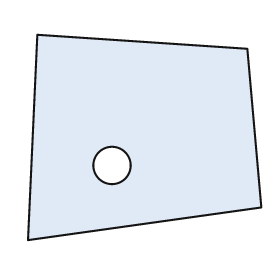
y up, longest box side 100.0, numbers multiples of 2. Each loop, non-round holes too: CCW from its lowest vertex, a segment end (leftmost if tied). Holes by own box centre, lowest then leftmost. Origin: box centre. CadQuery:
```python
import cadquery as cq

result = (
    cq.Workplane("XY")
    .moveTo(-50.0, -44.0)
    .lineTo(50.0, -30.0)
    .lineTo(44.0, 38.0)
    .lineTo(-46.0, 44.0)
    .close()
    .moveTo(-14.0, -12.0)
    .circle(8.0)
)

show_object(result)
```